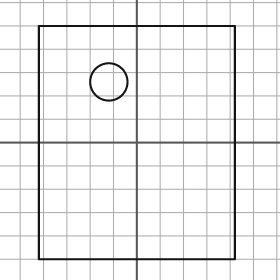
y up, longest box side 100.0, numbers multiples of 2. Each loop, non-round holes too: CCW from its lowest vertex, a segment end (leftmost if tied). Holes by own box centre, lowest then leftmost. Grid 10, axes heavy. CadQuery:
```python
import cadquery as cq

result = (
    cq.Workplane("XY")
    .moveTo(-42.0, -50.0)
    .lineTo(42.0, -50.0)
    .lineTo(42.0, 50.0)
    .lineTo(-42.0, 50.0)
    .close()
    .moveTo(-12.0, 26.0)
    .circle(8.0)
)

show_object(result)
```